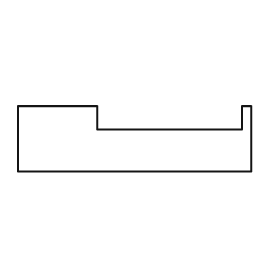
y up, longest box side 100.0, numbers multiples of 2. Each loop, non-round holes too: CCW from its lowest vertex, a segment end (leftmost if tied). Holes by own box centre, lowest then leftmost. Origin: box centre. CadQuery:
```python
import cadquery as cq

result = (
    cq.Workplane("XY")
    .moveTo(-50.0, -14.0)
    .lineTo(50.0, -14.0)
    .lineTo(50.0, 14.0)
    .lineTo(46.0, 14.0)
    .lineTo(46.0, 4.0)
    .lineTo(-16.0, 4.0)
    .lineTo(-16.0, 14.0)
    .lineTo(-50.0, 14.0)
    .close()
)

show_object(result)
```